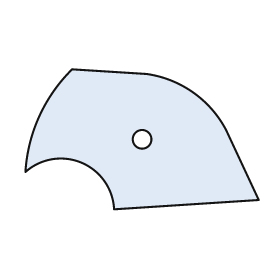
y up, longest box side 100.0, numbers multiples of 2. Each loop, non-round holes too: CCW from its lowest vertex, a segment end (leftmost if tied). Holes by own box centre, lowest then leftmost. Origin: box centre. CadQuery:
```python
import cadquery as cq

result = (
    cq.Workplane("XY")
    .moveTo(-12.0, -30.0)
    .lineTo(50.0, -26.0)
    .lineTo(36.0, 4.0)
    .threePointArc((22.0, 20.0), (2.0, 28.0))
    .lineTo(-30.0, 30.0)
    .threePointArc((-44.0, 10.0), (-50.0, -14.0))
    .threePointArc((-26.0, -10.0), (-12.0, -30.0))
    .close()
    .moveTo(0.0, 0.0)
    .circle(4.0)
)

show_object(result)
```